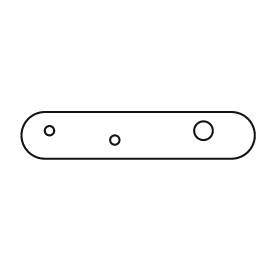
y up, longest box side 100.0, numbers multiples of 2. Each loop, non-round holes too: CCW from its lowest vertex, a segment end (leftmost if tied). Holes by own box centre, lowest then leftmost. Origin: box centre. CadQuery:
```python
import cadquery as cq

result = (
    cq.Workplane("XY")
    .moveTo(-40.0, -10.0)
    .lineTo(40.0, -10.0)
    .threePointArc((50.0, 0.0), (40.0, 10.0))
    .lineTo(-40.0, 10.0)
    .threePointArc((-50.0, 0.0), (-40.0, -10.0))
    .close()
    .moveTo(-10.0, -2.0)
    .circle(2.0)
    .moveTo(-38.0, 2.0)
    .circle(2.0)
    .moveTo(28.0, 2.0)
    .circle(4.0)
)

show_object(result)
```